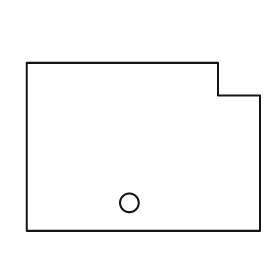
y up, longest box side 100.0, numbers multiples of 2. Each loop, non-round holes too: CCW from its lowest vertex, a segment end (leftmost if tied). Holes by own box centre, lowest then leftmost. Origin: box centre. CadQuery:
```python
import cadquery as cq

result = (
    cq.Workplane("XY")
    .moveTo(-50.0, -36.0)
    .lineTo(50.0, -36.0)
    .lineTo(50.0, 22.0)
    .lineTo(32.0, 22.0)
    .lineTo(32.0, 36.0)
    .lineTo(-50.0, 36.0)
    .close()
    .moveTo(-6.0, -24.0)
    .circle(4.0)
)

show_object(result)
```